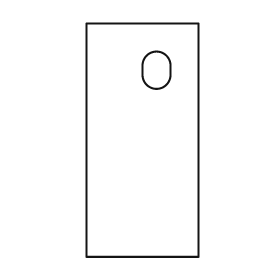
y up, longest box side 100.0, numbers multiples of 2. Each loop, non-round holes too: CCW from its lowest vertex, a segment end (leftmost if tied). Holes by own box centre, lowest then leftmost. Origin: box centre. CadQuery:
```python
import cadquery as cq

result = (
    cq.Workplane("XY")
    .moveTo(-24.0, -50.0)
    .lineTo(24.0, -50.0)
    .lineTo(24.0, 50.0)
    .lineTo(-24.0, 50.0)
    .close()
    .moveTo(0.0, 28.0)
    .threePointArc((6.0, 22.0), (12.0, 28.0))
    .lineTo(12.0, 32.0)
    .threePointArc((6.0, 38.0), (0.0, 32.0))
    .close()
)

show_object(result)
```